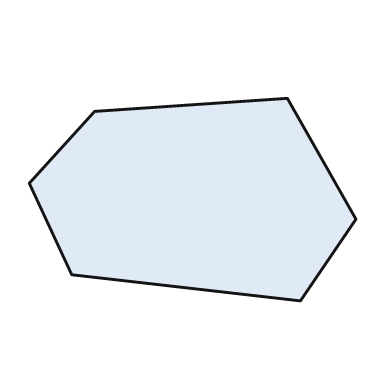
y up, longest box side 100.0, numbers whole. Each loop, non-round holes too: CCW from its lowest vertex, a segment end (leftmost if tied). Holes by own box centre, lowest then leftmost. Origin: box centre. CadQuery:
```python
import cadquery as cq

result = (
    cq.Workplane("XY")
    .moveTo(33.0, -31.0)
    .lineTo(50.0, -6.0)
    .lineTo(29.0, 31.0)
    .lineTo(-30.0, 27.0)
    .lineTo(-50.0, 5.0)
    .lineTo(-37.0, -23.0)
    .close()
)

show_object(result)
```